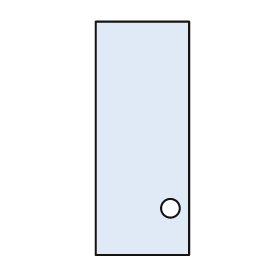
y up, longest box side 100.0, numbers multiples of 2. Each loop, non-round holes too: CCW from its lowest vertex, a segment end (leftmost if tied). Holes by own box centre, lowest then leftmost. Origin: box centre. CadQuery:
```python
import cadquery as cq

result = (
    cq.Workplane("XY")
    .moveTo(-20.0, -50.0)
    .lineTo(20.0, -50.0)
    .lineTo(20.0, 50.0)
    .lineTo(-20.0, 50.0)
    .close()
    .moveTo(12.0, -30.0)
    .circle(4.0)
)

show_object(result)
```